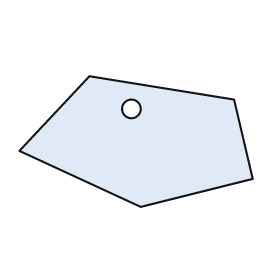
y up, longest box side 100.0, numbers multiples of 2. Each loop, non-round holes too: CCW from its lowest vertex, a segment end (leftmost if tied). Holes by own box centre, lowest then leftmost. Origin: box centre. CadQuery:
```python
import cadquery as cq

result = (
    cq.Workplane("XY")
    .moveTo(2.0, -28.0)
    .lineTo(50.0, -16.0)
    .lineTo(42.0, 18.0)
    .lineTo(-20.0, 28.0)
    .lineTo(-50.0, -4.0)
    .close()
    .moveTo(-2.0, 14.0)
    .circle(4.0)
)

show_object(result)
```